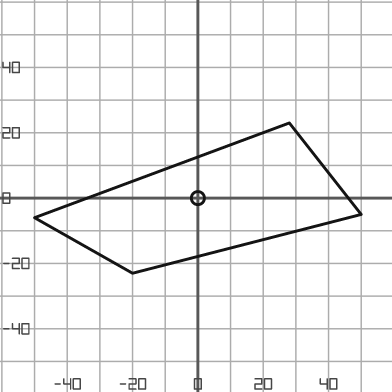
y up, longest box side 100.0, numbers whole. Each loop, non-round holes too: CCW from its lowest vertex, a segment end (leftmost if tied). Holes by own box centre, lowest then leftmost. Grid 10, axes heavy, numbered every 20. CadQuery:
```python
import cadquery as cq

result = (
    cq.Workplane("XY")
    .moveTo(-20.0, -23.0)
    .lineTo(50.0, -5.0)
    .lineTo(28.0, 23.0)
    .lineTo(-50.0, -6.0)
    .close()
    .moveTo(0.0, 0.0)
    .circle(2.0)
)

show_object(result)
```